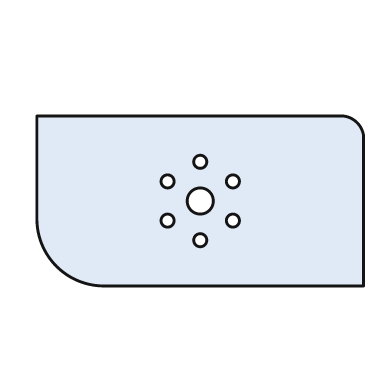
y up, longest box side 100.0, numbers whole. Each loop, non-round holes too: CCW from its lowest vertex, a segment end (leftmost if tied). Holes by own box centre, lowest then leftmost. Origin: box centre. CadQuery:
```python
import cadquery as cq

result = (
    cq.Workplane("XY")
    .moveTo(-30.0, -26.0)
    .lineTo(50.0, -26.0)
    .lineTo(50.0, 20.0)
    .threePointArc((48.0, 24.0), (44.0, 26.0))
    .lineTo(-50.0, 26.0)
    .lineTo(-50.0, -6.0)
    .threePointArc((-44.0, -20.0), (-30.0, -26.0))
    .close()
    .moveTo(0.0, -12.0)
    .circle(2.0)
    .moveTo(-10.0, -6.0)
    .circle(2.0)
    .moveTo(10.0, -6.0)
    .circle(2.0)
    .moveTo(0.0, 0.0)
    .circle(4.0)
    .moveTo(-10.0, 6.0)
    .circle(2.0)
    .moveTo(10.0, 6.0)
    .circle(2.0)
    .moveTo(0.0, 12.0)
    .circle(2.0)
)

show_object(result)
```